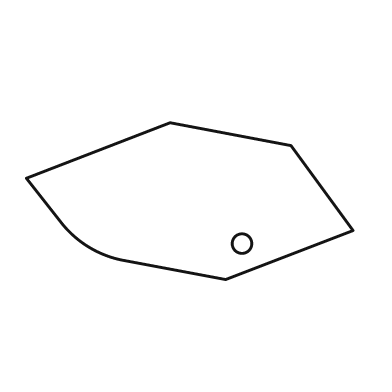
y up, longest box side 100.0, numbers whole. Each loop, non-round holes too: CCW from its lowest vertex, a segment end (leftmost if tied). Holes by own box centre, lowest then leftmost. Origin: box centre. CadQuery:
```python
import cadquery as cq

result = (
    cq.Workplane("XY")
    .moveTo(11.0, -24.0)
    .lineTo(50.0, -9.0)
    .lineTo(31.0, 17.0)
    .lineTo(-6.0, 24.0)
    .lineTo(-50.0, 7.0)
    .lineTo(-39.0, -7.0)
    .threePointArc((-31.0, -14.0), (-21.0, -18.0))
    .close()
    .moveTo(16.0, -13.0)
    .circle(3.0)
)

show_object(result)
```